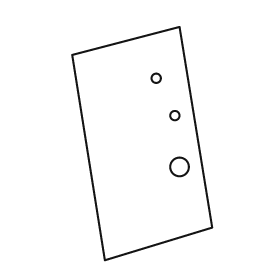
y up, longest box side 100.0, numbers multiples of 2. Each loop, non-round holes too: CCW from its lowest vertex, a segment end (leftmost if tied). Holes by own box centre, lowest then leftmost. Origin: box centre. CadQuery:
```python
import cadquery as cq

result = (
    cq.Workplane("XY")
    .moveTo(-16.0, -50.0)
    .lineTo(30.0, -36.0)
    .lineTo(16.0, 50.0)
    .lineTo(-30.0, 38.0)
    .close()
    .moveTo(16.0, -10.0)
    .circle(4.0)
    .moveTo(14.0, 12.0)
    .circle(2.0)
    .moveTo(6.0, 28.0)
    .circle(2.0)
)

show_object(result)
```